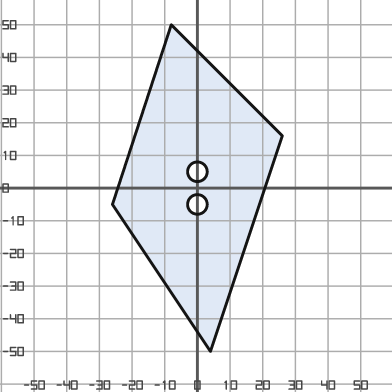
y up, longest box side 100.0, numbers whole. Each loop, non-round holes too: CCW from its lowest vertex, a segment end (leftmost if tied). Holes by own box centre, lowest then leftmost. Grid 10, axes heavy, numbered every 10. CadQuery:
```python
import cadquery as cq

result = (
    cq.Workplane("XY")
    .moveTo(4.0, -50.0)
    .lineTo(26.0, 16.0)
    .lineTo(-8.0, 50.0)
    .lineTo(-26.0, -5.0)
    .close()
    .moveTo(0.0, -5.0)
    .circle(3.0)
    .moveTo(0.0, 5.0)
    .circle(3.0)
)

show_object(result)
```